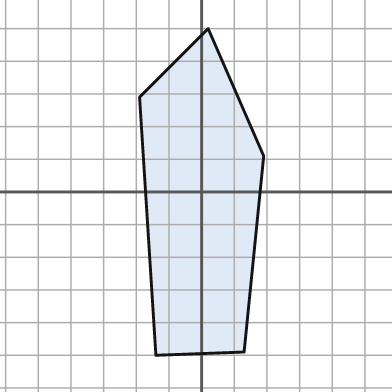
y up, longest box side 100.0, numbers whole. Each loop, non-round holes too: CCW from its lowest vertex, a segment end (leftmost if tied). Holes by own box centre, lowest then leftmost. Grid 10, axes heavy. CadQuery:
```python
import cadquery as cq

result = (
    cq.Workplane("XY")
    .moveTo(-14.0, -50.0)
    .lineTo(13.0, -49.0)
    .lineTo(19.0, 11.0)
    .lineTo(2.0, 50.0)
    .lineTo(-19.0, 29.0)
    .close()
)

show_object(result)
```